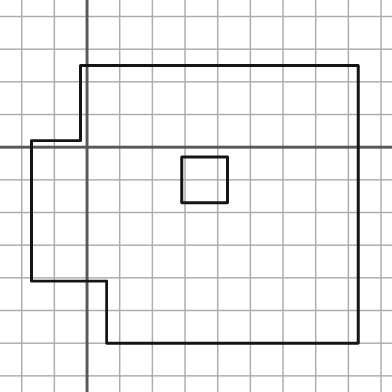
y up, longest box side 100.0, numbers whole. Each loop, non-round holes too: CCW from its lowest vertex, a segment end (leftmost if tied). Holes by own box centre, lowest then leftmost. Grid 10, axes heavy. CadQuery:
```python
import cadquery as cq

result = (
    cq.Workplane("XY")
    .moveTo(6.0, -60.0)
    .lineTo(83.0, -60.0)
    .lineTo(83.0, 25.0)
    .lineTo(-2.0, 25.0)
    .lineTo(-2.0, 2.0)
    .lineTo(-17.0, 2.0)
    .lineTo(-17.0, -41.0)
    .lineTo(6.0, -41.0)
    .close()
    .moveTo(29.0, -17.0)
    .lineTo(43.0, -17.0)
    .lineTo(43.0, -3.0)
    .lineTo(29.0, -3.0)
    .close()
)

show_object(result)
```